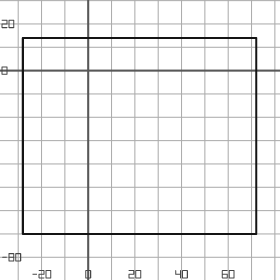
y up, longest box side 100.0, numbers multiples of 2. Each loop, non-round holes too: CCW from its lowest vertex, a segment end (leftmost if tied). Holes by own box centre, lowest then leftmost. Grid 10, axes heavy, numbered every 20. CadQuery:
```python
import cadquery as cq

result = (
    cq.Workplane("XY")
    .moveTo(-28.0, -70.0)
    .lineTo(72.0, -70.0)
    .lineTo(72.0, 14.0)
    .lineTo(-28.0, 14.0)
    .close()
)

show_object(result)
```